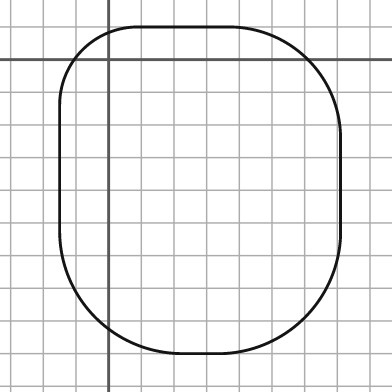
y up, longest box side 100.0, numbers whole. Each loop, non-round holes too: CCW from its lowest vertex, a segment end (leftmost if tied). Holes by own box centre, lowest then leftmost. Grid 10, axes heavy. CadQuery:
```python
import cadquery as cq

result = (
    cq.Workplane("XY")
    .moveTo(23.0, -90.0)
    .lineTo(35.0, -90.0)
    .threePointArc((60.0, -79.0), (71.0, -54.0))
    .lineTo(71.0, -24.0)
    .threePointArc((61.0, 0.0), (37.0, 10.0))
    .lineTo(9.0, 10.0)
    .threePointArc((-8.0, 3.0), (-15.0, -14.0))
    .lineTo(-15.0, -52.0)
    .threePointArc((-4.0, -79.0), (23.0, -90.0))
    .close()
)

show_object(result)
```